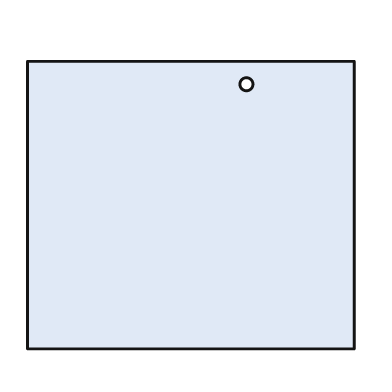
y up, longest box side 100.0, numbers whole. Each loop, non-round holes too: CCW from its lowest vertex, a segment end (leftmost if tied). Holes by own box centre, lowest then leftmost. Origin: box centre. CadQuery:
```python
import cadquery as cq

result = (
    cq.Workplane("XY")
    .moveTo(-50.0, -44.0)
    .lineTo(50.0, -44.0)
    .lineTo(50.0, 44.0)
    .lineTo(-50.0, 44.0)
    .close()
    .moveTo(17.0, 37.0)
    .circle(2.0)
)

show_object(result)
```